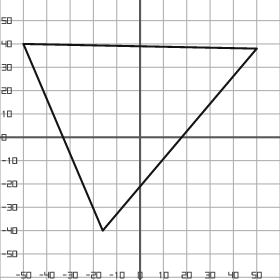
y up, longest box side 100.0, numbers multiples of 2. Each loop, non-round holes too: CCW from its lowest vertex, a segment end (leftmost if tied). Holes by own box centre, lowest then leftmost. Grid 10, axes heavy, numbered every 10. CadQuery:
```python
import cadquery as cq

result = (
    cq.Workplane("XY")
    .moveTo(-16.0, -40.0)
    .lineTo(50.0, 38.0)
    .lineTo(-50.0, 40.0)
    .close()
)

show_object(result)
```